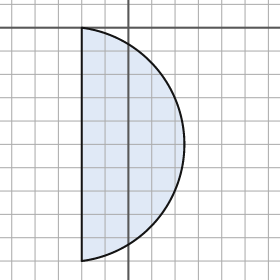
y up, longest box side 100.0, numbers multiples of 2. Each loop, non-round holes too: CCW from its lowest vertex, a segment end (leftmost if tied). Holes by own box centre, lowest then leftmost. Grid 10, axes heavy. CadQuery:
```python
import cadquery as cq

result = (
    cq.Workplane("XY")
    .moveTo(-20.0, -100.0)
    .threePointArc((24.0, -50.0), (-20.0, 0.0))
    .close()
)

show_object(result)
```